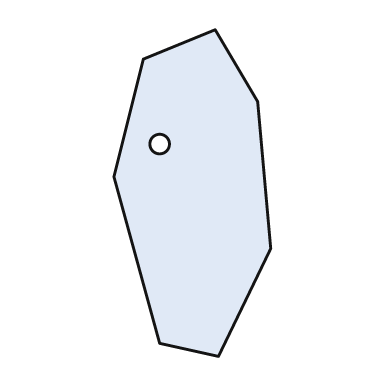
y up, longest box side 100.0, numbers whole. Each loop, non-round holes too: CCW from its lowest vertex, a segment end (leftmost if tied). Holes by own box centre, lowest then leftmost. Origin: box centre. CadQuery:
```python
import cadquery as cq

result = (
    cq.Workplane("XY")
    .moveTo(8.0, -50.0)
    .lineTo(24.0, -17.0)
    .lineTo(20.0, 28.0)
    .lineTo(7.0, 50.0)
    .lineTo(-15.0, 41.0)
    .lineTo(-24.0, 5.0)
    .lineTo(-10.0, -46.0)
    .close()
    .moveTo(-10.0, 15.0)
    .circle(3.0)
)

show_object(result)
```